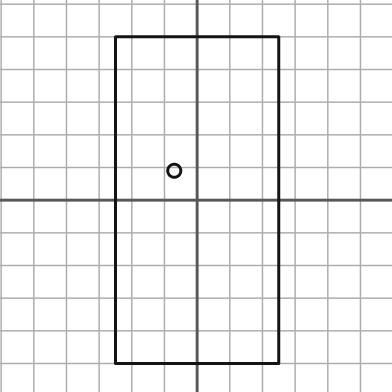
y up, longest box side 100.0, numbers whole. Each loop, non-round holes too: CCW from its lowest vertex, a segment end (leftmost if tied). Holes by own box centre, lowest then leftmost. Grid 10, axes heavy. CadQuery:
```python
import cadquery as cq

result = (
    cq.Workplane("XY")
    .moveTo(-25.0, -50.0)
    .lineTo(25.0, -50.0)
    .lineTo(25.0, 50.0)
    .lineTo(-25.0, 50.0)
    .close()
    .moveTo(-7.0, 9.0)
    .circle(2.0)
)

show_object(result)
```